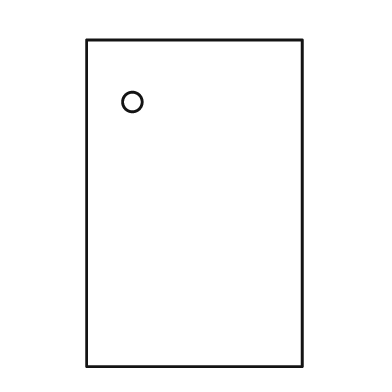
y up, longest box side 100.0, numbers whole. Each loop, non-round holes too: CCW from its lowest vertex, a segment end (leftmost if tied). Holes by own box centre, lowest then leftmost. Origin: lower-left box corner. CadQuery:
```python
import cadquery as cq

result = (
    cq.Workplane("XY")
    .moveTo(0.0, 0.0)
    .lineTo(66.0, 0.0)
    .lineTo(66.0, 100.0)
    .lineTo(0.0, 100.0)
    .close()
    .moveTo(14.0, 81.0)
    .circle(3.0)
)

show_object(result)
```